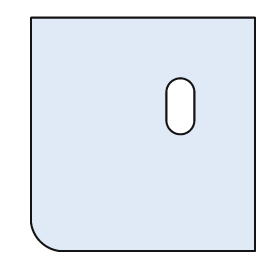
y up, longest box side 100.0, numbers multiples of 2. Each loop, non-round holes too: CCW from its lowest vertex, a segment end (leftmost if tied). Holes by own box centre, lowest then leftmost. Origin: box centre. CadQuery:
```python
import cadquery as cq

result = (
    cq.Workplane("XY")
    .moveTo(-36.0, -50.0)
    .lineTo(48.0, -50.0)
    .lineTo(48.0, 50.0)
    .lineTo(-48.0, 50.0)
    .lineTo(-48.0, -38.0)
    .threePointArc((-44.0, -46.0), (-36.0, -50.0))
    .close()
    .moveTo(10.0, 6.0)
    .threePointArc((16.0, 0.0), (22.0, 6.0))
    .lineTo(22.0, 18.0)
    .threePointArc((16.0, 24.0), (10.0, 18.0))
    .close()
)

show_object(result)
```